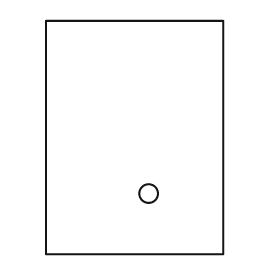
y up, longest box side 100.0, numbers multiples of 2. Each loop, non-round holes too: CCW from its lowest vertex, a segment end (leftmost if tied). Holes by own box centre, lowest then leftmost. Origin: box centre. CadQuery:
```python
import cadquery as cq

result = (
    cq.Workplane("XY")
    .moveTo(-38.0, -50.0)
    .lineTo(38.0, -50.0)
    .lineTo(38.0, 50.0)
    .lineTo(-38.0, 50.0)
    .close()
    .moveTo(6.0, -24.0)
    .circle(4.0)
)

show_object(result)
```